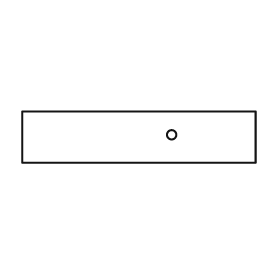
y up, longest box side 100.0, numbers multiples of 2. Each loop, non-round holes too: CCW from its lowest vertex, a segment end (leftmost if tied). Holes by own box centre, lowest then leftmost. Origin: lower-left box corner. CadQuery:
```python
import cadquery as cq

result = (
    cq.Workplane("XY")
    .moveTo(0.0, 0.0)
    .lineTo(100.0, 0.0)
    .lineTo(100.0, 22.0)
    .lineTo(0.0, 22.0)
    .close()
    .moveTo(64.0, 12.0)
    .circle(2.0)
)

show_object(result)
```